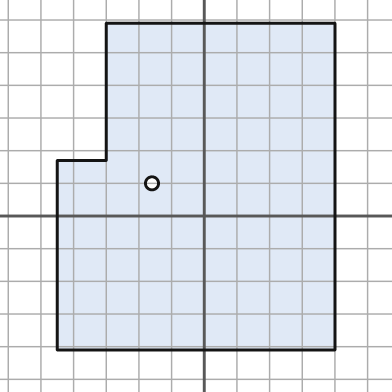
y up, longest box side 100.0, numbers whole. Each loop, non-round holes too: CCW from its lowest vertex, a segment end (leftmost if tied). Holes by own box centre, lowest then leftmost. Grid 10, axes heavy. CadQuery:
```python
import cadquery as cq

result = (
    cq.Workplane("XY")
    .moveTo(-45.0, -41.0)
    .lineTo(40.0, -41.0)
    .lineTo(40.0, 59.0)
    .lineTo(-30.0, 59.0)
    .lineTo(-30.0, 17.0)
    .lineTo(-45.0, 17.0)
    .close()
    .moveTo(-16.0, 10.0)
    .circle(2.0)
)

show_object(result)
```